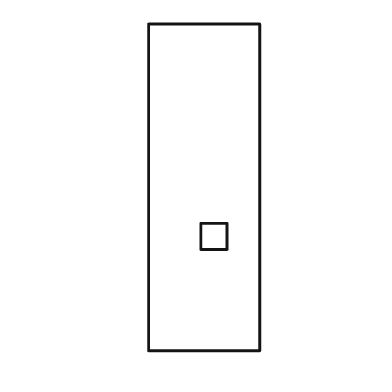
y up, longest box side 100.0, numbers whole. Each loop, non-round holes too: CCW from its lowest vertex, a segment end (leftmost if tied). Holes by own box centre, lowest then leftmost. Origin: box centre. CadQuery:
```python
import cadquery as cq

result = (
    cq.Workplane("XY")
    .moveTo(-17.0, -50.0)
    .lineTo(17.0, -50.0)
    .lineTo(17.0, 50.0)
    .lineTo(-17.0, 50.0)
    .close()
    .moveTo(-1.0, -19.0)
    .lineTo(7.0, -19.0)
    .lineTo(7.0, -11.0)
    .lineTo(-1.0, -11.0)
    .close()
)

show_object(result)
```